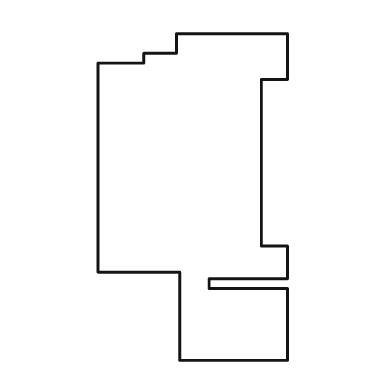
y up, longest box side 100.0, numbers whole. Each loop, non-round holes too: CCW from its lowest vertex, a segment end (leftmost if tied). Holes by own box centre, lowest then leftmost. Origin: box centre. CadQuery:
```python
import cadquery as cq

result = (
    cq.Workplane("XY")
    .moveTo(-4.0, -50.0)
    .lineTo(29.0, -50.0)
    .lineTo(29.0, -28.0)
    .lineTo(5.0, -28.0)
    .lineTo(5.0, -25.0)
    .lineTo(29.0, -25.0)
    .lineTo(29.0, -15.0)
    .lineTo(21.0, -15.0)
    .lineTo(21.0, 36.0)
    .lineTo(29.0, 36.0)
    .lineTo(29.0, 50.0)
    .lineTo(-5.0, 50.0)
    .lineTo(-5.0, 44.0)
    .lineTo(-15.0, 44.0)
    .lineTo(-15.0, 41.0)
    .lineTo(-29.0, 41.0)
    .lineTo(-29.0, -23.0)
    .lineTo(-4.0, -23.0)
    .close()
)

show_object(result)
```